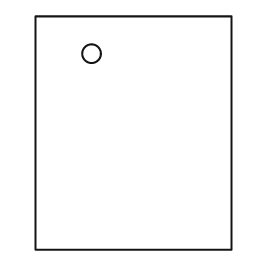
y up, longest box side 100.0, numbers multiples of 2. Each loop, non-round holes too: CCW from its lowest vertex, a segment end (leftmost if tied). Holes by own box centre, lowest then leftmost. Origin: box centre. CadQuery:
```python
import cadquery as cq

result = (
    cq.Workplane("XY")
    .moveTo(-42.0, -50.0)
    .lineTo(42.0, -50.0)
    .lineTo(42.0, 50.0)
    .lineTo(-42.0, 50.0)
    .close()
    .moveTo(-18.0, 34.0)
    .circle(4.0)
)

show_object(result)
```